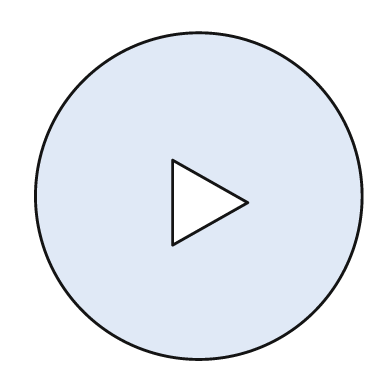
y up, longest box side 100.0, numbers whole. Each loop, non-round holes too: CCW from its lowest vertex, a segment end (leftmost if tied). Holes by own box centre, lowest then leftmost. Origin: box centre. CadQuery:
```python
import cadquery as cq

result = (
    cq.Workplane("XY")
    .moveTo(0.0, 0.0)
    .circle(50.0)
    .moveTo(-8.0, -15.0)
    .lineTo(15.0, -2.0)
    .lineTo(-8.0, 11.0)
    .close()
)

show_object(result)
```